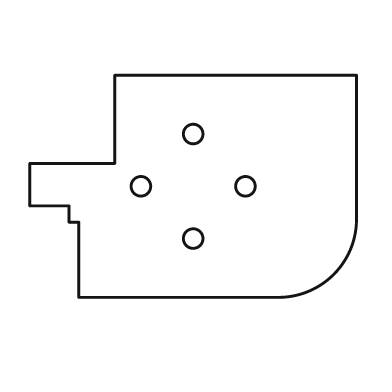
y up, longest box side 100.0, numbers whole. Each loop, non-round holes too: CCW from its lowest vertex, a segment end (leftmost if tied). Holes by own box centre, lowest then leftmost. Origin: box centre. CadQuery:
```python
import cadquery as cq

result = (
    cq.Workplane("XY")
    .moveTo(-35.0, -34.0)
    .lineTo(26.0, -34.0)
    .threePointArc((43.0, -27.0), (50.0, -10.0))
    .lineTo(50.0, 34.0)
    .lineTo(-24.0, 34.0)
    .lineTo(-24.0, 7.0)
    .lineTo(-50.0, 7.0)
    .lineTo(-50.0, -6.0)
    .lineTo(-38.0, -6.0)
    .lineTo(-38.0, -11.0)
    .lineTo(-35.0, -11.0)
    .close()
    .moveTo(0.0, -16.0)
    .circle(3.0)
    .moveTo(-16.0, 0.0)
    .circle(3.0)
    .moveTo(16.0, 0.0)
    .circle(3.0)
    .moveTo(0.0, 16.0)
    .circle(3.0)
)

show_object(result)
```